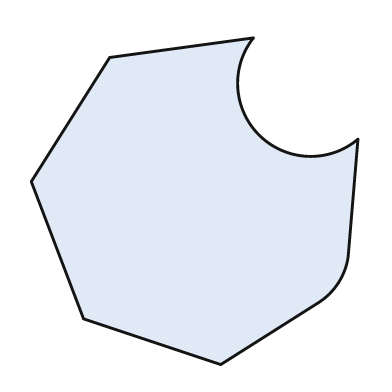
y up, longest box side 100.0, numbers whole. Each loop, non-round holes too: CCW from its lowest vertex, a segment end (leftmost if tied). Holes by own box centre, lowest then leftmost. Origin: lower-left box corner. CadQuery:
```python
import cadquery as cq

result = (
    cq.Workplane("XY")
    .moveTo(58.0, 0.0)
    .lineTo(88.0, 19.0)
    .threePointArc((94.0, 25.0), (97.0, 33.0))
    .lineTo(100.0, 69.0)
    .threePointArc((70.0, 70.0), (68.0, 100.0))
    .lineTo(24.0, 94.0)
    .lineTo(0.0, 56.0)
    .lineTo(16.0, 14.0)
    .close()
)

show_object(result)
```